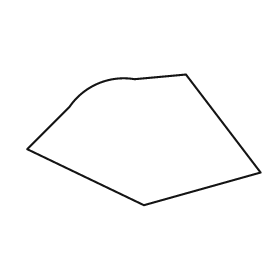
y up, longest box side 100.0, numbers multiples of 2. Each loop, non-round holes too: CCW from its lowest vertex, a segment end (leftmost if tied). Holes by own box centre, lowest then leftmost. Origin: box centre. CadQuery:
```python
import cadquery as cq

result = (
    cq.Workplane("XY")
    .moveTo(0.0, -28.0)
    .lineTo(50.0, -14.0)
    .lineTo(18.0, 28.0)
    .lineTo(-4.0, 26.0)
    .threePointArc((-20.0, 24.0), (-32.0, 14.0))
    .lineTo(-50.0, -4.0)
    .close()
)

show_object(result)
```